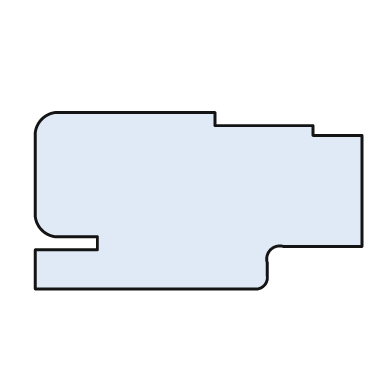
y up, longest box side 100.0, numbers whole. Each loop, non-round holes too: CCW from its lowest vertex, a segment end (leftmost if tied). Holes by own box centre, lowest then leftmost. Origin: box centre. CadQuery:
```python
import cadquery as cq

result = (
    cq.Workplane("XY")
    .moveTo(-50.0, -27.0)
    .lineTo(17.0, -27.0)
    .threePointArc((20.0, -26.0), (21.0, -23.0))
    .lineTo(21.0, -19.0)
    .threePointArc((22.0, -15.0), (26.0, -14.0))
    .lineTo(50.0, -14.0)
    .lineTo(50.0, 20.0)
    .lineTo(35.0, 20.0)
    .lineTo(35.0, 23.0)
    .lineTo(5.0, 23.0)
    .lineTo(5.0, 27.0)
    .lineTo(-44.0, 27.0)
    .threePointArc((-48.0, 25.0), (-50.0, 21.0))
    .lineTo(-50.0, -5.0)
    .threePointArc((-48.0, -9.0), (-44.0, -11.0))
    .lineTo(-31.0, -11.0)
    .lineTo(-31.0, -15.0)
    .lineTo(-50.0, -15.0)
    .close()
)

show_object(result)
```